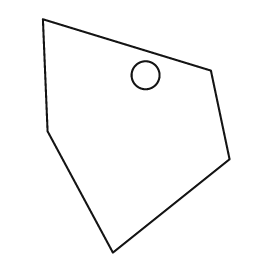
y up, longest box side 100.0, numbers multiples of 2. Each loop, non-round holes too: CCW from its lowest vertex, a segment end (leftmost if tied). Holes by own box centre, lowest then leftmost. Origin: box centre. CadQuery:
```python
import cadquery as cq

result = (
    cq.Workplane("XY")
    .moveTo(-10.0, -50.0)
    .lineTo(40.0, -10.0)
    .lineTo(32.0, 28.0)
    .lineTo(-40.0, 50.0)
    .lineTo(-38.0, 2.0)
    .close()
    .moveTo(4.0, 26.0)
    .circle(6.0)
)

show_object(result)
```